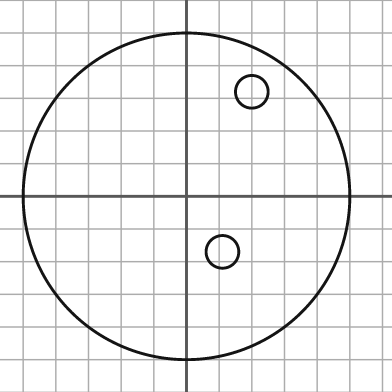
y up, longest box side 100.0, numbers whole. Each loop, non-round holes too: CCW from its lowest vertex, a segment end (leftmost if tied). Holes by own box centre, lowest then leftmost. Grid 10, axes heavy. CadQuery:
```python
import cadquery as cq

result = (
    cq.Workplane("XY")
    .moveTo(0.0, 0.0)
    .circle(50.0)
    .moveTo(11.0, -17.0)
    .circle(5.0)
    .moveTo(20.0, 32.0)
    .circle(5.0)
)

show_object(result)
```